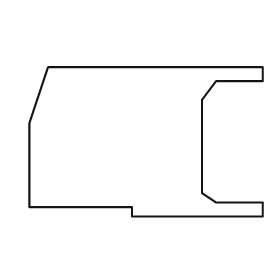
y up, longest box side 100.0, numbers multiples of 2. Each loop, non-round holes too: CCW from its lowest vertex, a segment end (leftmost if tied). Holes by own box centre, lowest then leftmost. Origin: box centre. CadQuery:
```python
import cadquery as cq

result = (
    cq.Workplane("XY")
    .moveTo(-6.0, -32.0)
    .lineTo(50.0, -32.0)
    .lineTo(50.0, -26.0)
    .lineTo(30.0, -26.0)
    .lineTo(24.0, -22.0)
    .lineTo(24.0, 18.0)
    .lineTo(30.0, 26.0)
    .lineTo(50.0, 26.0)
    .lineTo(50.0, 32.0)
    .lineTo(-42.0, 32.0)
    .lineTo(-50.0, 8.0)
    .lineTo(-50.0, -28.0)
    .lineTo(-6.0, -28.0)
    .close()
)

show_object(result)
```